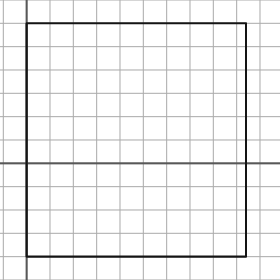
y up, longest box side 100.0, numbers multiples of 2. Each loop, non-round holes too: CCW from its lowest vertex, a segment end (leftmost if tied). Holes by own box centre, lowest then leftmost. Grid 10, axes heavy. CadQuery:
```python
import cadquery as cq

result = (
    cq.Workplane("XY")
    .moveTo(0.0, -40.0)
    .lineTo(94.0, -40.0)
    .lineTo(94.0, 60.0)
    .lineTo(0.0, 60.0)
    .close()
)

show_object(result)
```